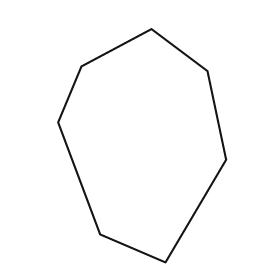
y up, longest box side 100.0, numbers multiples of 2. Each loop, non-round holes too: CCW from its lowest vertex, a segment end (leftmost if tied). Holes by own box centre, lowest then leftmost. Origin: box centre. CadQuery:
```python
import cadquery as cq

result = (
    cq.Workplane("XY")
    .moveTo(10.0, -50.0)
    .lineTo(36.0, -6.0)
    .lineTo(28.0, 32.0)
    .lineTo(4.0, 50.0)
    .lineTo(-26.0, 34.0)
    .lineTo(-36.0, 10.0)
    .lineTo(-18.0, -38.0)
    .close()
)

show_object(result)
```